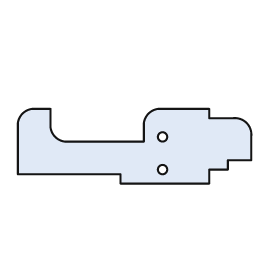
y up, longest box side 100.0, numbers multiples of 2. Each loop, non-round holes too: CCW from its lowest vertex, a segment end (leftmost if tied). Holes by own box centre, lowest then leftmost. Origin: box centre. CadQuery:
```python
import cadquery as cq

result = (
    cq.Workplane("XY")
    .moveTo(-6.0, -16.0)
    .lineTo(32.0, -16.0)
    .lineTo(32.0, -10.0)
    .lineTo(40.0, -10.0)
    .lineTo(40.0, -6.0)
    .lineTo(50.0, -6.0)
    .lineTo(50.0, 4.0)
    .threePointArc((48.0, 10.0), (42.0, 12.0))
    .lineTo(32.0, 12.0)
    .lineTo(32.0, 16.0)
    .lineTo(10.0, 16.0)
    .threePointArc((6.0, 14.0), (4.0, 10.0))
    .lineTo(4.0, 2.0)
    .lineTo(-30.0, 2.0)
    .threePointArc((-34.0, 4.0), (-36.0, 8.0))
    .lineTo(-36.0, 16.0)
    .lineTo(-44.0, 16.0)
    .threePointArc((-48.0, 14.0), (-50.0, 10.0))
    .lineTo(-50.0, -12.0)
    .lineTo(-6.0, -12.0)
    .close()
    .moveTo(12.0, -10.0)
    .circle(2.0)
    .moveTo(12.0, 4.0)
    .circle(2.0)
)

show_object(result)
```